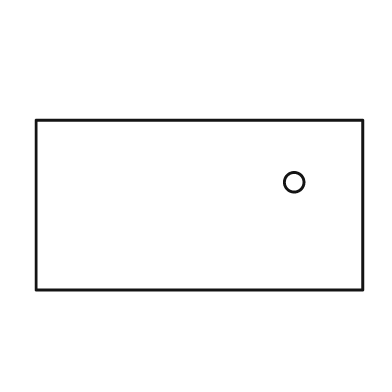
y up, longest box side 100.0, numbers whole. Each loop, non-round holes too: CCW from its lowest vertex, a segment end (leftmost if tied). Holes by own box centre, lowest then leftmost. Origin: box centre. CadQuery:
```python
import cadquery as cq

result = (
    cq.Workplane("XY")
    .moveTo(-50.0, -26.0)
    .lineTo(50.0, -26.0)
    .lineTo(50.0, 26.0)
    .lineTo(-50.0, 26.0)
    .close()
    .moveTo(29.0, 7.0)
    .circle(3.0)
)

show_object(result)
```